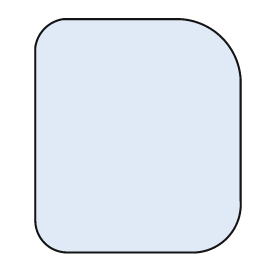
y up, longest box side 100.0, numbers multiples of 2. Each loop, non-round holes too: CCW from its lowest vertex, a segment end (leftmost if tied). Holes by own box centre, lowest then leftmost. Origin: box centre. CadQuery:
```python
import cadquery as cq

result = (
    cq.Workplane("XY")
    .moveTo(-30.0, -50.0)
    .lineTo(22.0, -50.0)
    .threePointArc((38.0, -44.0), (44.0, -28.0))
    .lineTo(44.0, 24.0)
    .threePointArc((36.0, 42.0), (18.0, 50.0))
    .lineTo(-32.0, 50.0)
    .threePointArc((-40.0, 46.0), (-44.0, 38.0))
    .lineTo(-44.0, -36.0)
    .threePointArc((-40.0, -46.0), (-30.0, -50.0))
    .close()
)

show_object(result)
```